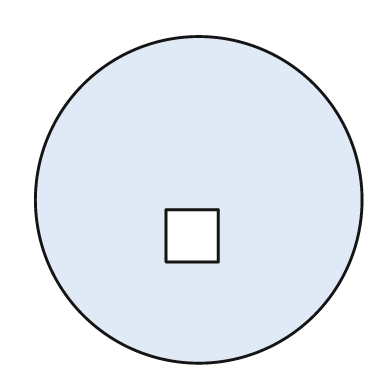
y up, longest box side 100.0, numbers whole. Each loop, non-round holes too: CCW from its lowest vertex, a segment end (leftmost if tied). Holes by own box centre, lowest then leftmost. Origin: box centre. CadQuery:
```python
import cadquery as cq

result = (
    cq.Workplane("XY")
    .moveTo(0.0, 0.0)
    .circle(50.0)
    .moveTo(-10.0, -19.0)
    .lineTo(6.0, -19.0)
    .lineTo(6.0, -3.0)
    .lineTo(-10.0, -3.0)
    .close()
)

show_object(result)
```